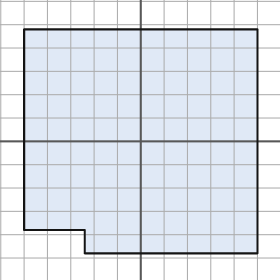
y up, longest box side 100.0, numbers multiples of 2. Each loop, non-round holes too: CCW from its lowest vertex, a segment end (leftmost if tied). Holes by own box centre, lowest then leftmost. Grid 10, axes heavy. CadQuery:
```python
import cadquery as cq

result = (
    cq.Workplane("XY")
    .moveTo(-24.0, -48.0)
    .lineTo(50.0, -48.0)
    .lineTo(50.0, 48.0)
    .lineTo(-50.0, 48.0)
    .lineTo(-50.0, -38.0)
    .lineTo(-24.0, -38.0)
    .close()
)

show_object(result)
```